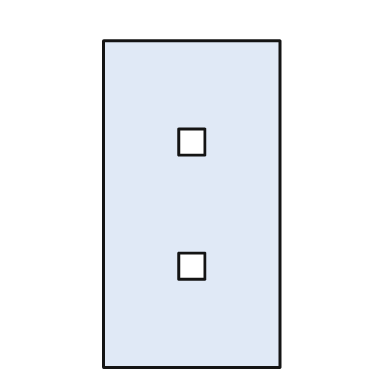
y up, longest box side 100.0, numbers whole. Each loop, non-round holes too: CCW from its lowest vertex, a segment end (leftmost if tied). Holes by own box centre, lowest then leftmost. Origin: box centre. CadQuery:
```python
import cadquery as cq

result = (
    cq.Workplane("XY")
    .moveTo(-27.0, -50.0)
    .lineTo(27.0, -50.0)
    .lineTo(27.0, 50.0)
    .lineTo(-27.0, 50.0)
    .close()
    .moveTo(-4.0, -23.0)
    .lineTo(4.0, -23.0)
    .lineTo(4.0, -15.0)
    .lineTo(-4.0, -15.0)
    .close()
    .moveTo(-4.0, 15.0)
    .lineTo(4.0, 15.0)
    .lineTo(4.0, 23.0)
    .lineTo(-4.0, 23.0)
    .close()
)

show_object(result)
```